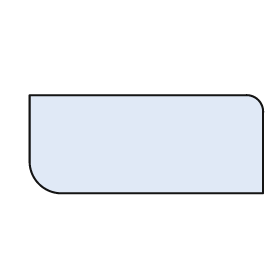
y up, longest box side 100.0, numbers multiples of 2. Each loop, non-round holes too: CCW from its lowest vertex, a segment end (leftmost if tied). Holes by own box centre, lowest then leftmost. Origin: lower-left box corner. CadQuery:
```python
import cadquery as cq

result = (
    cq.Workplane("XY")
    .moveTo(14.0, 0.0)
    .lineTo(100.0, 0.0)
    .lineTo(100.0, 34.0)
    .threePointArc((98.0, 40.0), (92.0, 42.0))
    .lineTo(0.0, 42.0)
    .lineTo(0.0, 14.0)
    .threePointArc((4.0, 4.0), (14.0, 0.0))
    .close()
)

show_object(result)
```